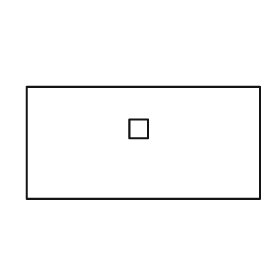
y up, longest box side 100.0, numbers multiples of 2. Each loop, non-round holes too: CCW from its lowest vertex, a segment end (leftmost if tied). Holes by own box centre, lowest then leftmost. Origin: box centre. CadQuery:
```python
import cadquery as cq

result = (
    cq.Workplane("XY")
    .moveTo(-50.0, -24.0)
    .lineTo(50.0, -24.0)
    .lineTo(50.0, 24.0)
    .lineTo(-50.0, 24.0)
    .close()
    .moveTo(-6.0, 2.0)
    .lineTo(2.0, 2.0)
    .lineTo(2.0, 10.0)
    .lineTo(-6.0, 10.0)
    .close()
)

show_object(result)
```